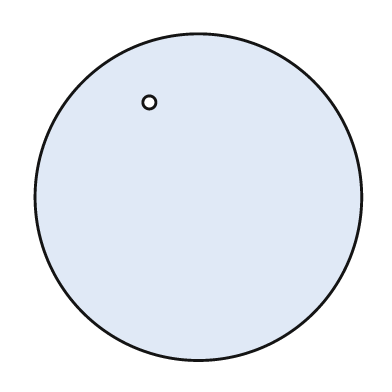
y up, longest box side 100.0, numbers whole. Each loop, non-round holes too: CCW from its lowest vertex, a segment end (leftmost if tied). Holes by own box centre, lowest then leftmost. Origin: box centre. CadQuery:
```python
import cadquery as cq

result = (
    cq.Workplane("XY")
    .moveTo(0.0, 0.0)
    .circle(50.0)
    .moveTo(-15.0, 29.0)
    .circle(2.0)
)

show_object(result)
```